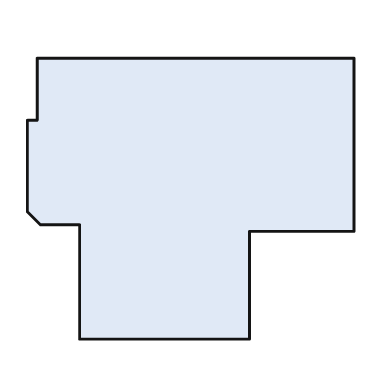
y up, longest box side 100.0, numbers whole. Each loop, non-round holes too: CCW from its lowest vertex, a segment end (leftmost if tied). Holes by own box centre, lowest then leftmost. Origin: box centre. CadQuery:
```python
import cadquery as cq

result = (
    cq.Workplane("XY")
    .moveTo(-34.0, -43.0)
    .lineTo(18.0, -43.0)
    .lineTo(18.0, -10.0)
    .lineTo(50.0, -10.0)
    .lineTo(50.0, 43.0)
    .lineTo(-47.0, 43.0)
    .lineTo(-47.0, 24.0)
    .lineTo(-50.0, 24.0)
    .lineTo(-50.0, -4.0)
    .lineTo(-46.0, -8.0)
    .lineTo(-34.0, -8.0)
    .close()
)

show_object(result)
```